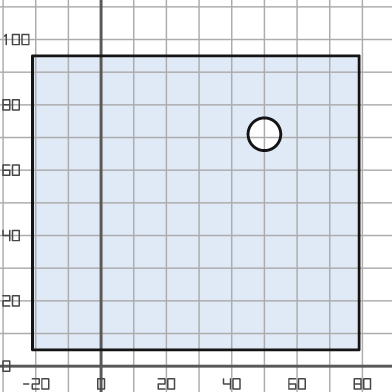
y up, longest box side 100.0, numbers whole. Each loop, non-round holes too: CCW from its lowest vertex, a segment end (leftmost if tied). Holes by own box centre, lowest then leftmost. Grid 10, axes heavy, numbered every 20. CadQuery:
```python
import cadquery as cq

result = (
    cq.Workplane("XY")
    .moveTo(-21.0, 5.0)
    .lineTo(79.0, 5.0)
    .lineTo(79.0, 95.0)
    .lineTo(-21.0, 95.0)
    .close()
    .moveTo(50.0, 71.0)
    .circle(5.0)
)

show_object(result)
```